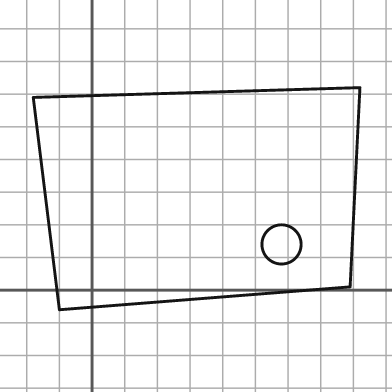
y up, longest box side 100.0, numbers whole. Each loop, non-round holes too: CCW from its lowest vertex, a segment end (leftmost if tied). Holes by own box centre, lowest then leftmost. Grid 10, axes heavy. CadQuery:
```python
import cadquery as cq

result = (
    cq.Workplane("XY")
    .moveTo(-10.0, -6.0)
    .lineTo(79.0, 1.0)
    .lineTo(82.0, 62.0)
    .lineTo(-18.0, 59.0)
    .close()
    .moveTo(58.0, 14.0)
    .circle(6.0)
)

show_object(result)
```